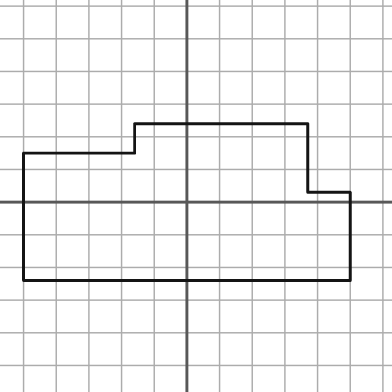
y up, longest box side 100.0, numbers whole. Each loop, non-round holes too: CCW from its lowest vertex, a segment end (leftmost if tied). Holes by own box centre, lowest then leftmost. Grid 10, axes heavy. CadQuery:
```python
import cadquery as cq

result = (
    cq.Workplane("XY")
    .moveTo(-50.0, -24.0)
    .lineTo(50.0, -24.0)
    .lineTo(50.0, 3.0)
    .lineTo(37.0, 3.0)
    .lineTo(37.0, 24.0)
    .lineTo(-16.0, 24.0)
    .lineTo(-16.0, 15.0)
    .lineTo(-50.0, 15.0)
    .close()
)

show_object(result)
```